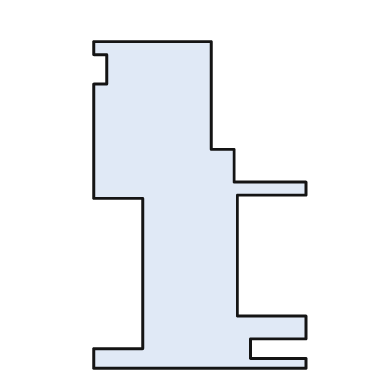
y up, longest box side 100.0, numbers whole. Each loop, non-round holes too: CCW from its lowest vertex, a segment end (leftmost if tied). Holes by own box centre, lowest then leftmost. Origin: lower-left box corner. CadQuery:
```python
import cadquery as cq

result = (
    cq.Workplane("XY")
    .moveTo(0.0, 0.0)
    .lineTo(65.0, 0.0)
    .lineTo(65.0, 3.0)
    .lineTo(48.0, 3.0)
    .lineTo(48.0, 9.0)
    .lineTo(65.0, 9.0)
    .lineTo(65.0, 16.0)
    .lineTo(44.0, 16.0)
    .lineTo(44.0, 53.0)
    .lineTo(65.0, 53.0)
    .lineTo(65.0, 57.0)
    .lineTo(43.0, 57.0)
    .lineTo(43.0, 67.0)
    .lineTo(36.0, 67.0)
    .lineTo(36.0, 100.0)
    .lineTo(0.0, 100.0)
    .lineTo(0.0, 96.0)
    .lineTo(4.0, 96.0)
    .lineTo(4.0, 87.0)
    .lineTo(0.0, 87.0)
    .lineTo(0.0, 52.0)
    .lineTo(15.0, 52.0)
    .lineTo(15.0, 6.0)
    .lineTo(0.0, 6.0)
    .close()
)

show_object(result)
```